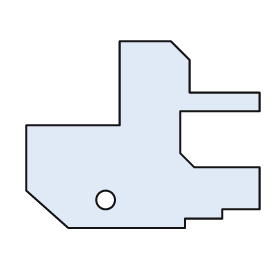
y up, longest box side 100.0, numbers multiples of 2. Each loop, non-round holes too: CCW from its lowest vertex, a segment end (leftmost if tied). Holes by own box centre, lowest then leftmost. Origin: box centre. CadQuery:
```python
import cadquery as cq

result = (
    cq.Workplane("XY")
    .moveTo(-32.0, -40.0)
    .lineTo(18.0, -40.0)
    .lineTo(18.0, -36.0)
    .lineTo(34.0, -36.0)
    .lineTo(34.0, -32.0)
    .lineTo(50.0, -32.0)
    .lineTo(50.0, -14.0)
    .lineTo(22.0, -14.0)
    .lineTo(16.0, -8.0)
    .lineTo(16.0, 10.0)
    .lineTo(50.0, 10.0)
    .lineTo(50.0, 18.0)
    .lineTo(20.0, 18.0)
    .lineTo(20.0, 32.0)
    .lineTo(12.0, 40.0)
    .lineTo(-10.0, 40.0)
    .lineTo(-10.0, 4.0)
    .lineTo(-50.0, 4.0)
    .lineTo(-50.0, -24.0)
    .close()
    .moveTo(-16.0, -28.0)
    .circle(4.0)
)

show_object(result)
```